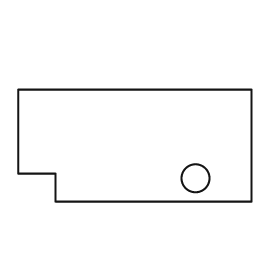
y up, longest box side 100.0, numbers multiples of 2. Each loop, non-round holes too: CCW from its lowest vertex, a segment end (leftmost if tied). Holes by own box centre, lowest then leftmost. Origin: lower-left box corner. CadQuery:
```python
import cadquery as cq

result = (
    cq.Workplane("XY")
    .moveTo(16.0, 0.0)
    .lineTo(100.0, 0.0)
    .lineTo(100.0, 48.0)
    .lineTo(0.0, 48.0)
    .lineTo(0.0, 12.0)
    .lineTo(16.0, 12.0)
    .close()
    .moveTo(76.0, 10.0)
    .circle(6.0)
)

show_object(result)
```